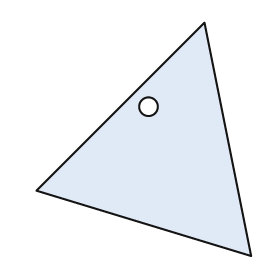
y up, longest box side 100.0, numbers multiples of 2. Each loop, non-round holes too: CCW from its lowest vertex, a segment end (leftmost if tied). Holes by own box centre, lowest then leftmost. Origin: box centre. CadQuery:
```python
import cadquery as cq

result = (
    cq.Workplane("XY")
    .moveTo(46.0, -50.0)
    .lineTo(26.0, 50.0)
    .lineTo(-46.0, -22.0)
    .close()
    .moveTo(2.0, 14.0)
    .circle(4.0)
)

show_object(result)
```